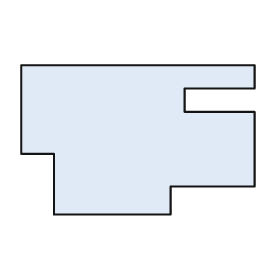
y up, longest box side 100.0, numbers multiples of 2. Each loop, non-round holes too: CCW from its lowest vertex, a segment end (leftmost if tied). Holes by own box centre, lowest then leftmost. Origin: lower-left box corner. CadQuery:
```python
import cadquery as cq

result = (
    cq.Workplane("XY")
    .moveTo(14.0, 0.0)
    .lineTo(64.0, 0.0)
    .lineTo(64.0, 12.0)
    .lineTo(100.0, 12.0)
    .lineTo(100.0, 44.0)
    .lineTo(70.0, 44.0)
    .lineTo(70.0, 54.0)
    .lineTo(100.0, 54.0)
    .lineTo(100.0, 64.0)
    .lineTo(0.0, 64.0)
    .lineTo(0.0, 26.0)
    .lineTo(14.0, 26.0)
    .close()
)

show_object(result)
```